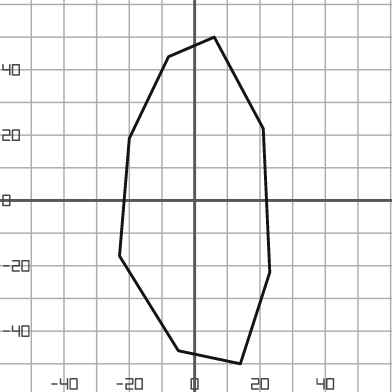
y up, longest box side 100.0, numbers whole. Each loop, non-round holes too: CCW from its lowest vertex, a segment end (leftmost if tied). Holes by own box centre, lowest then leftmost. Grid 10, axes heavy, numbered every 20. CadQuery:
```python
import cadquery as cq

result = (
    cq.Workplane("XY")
    .moveTo(14.0, -50.0)
    .lineTo(23.0, -22.0)
    .lineTo(21.0, 22.0)
    .lineTo(6.0, 50.0)
    .lineTo(-8.0, 44.0)
    .lineTo(-20.0, 19.0)
    .lineTo(-23.0, -17.0)
    .lineTo(-5.0, -46.0)
    .close()
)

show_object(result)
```